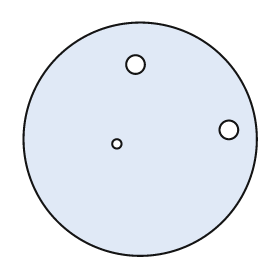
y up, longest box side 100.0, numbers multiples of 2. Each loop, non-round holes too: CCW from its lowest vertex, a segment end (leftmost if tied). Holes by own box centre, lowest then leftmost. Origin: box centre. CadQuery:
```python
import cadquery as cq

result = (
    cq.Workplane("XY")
    .moveTo(0.0, 0.0)
    .circle(50.0)
    .moveTo(-10.0, -2.0)
    .circle(2.0)
    .moveTo(38.0, 4.0)
    .circle(4.0)
    .moveTo(-2.0, 32.0)
    .circle(4.0)
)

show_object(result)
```